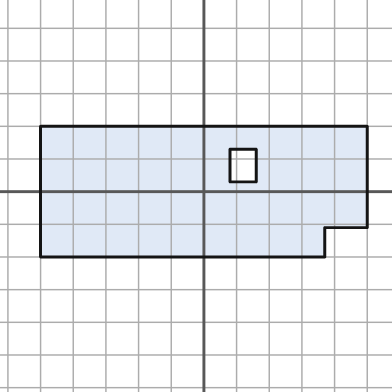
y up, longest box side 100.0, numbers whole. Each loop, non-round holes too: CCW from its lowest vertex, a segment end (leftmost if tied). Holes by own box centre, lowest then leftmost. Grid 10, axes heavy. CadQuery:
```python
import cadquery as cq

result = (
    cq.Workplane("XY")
    .moveTo(-50.0, -20.0)
    .lineTo(37.0, -20.0)
    .lineTo(37.0, -11.0)
    .lineTo(50.0, -11.0)
    .lineTo(50.0, 20.0)
    .lineTo(-50.0, 20.0)
    .close()
    .moveTo(8.0, 3.0)
    .lineTo(16.0, 3.0)
    .lineTo(16.0, 13.0)
    .lineTo(8.0, 13.0)
    .close()
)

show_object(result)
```